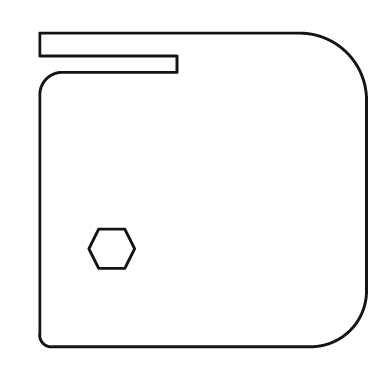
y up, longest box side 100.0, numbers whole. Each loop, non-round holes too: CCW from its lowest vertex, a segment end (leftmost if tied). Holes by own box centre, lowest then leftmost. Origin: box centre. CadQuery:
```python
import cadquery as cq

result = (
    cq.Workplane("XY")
    .moveTo(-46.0, -48.0)
    .lineTo(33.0, -48.0)
    .threePointArc((45.0, -43.0), (50.0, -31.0))
    .lineTo(50.0, 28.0)
    .threePointArc((44.0, 42.0), (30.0, 48.0))
    .lineTo(-50.0, 48.0)
    .lineTo(-50.0, 41.0)
    .lineTo(-8.0, 41.0)
    .lineTo(-8.0, 36.0)
    .lineTo(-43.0, 36.0)
    .threePointArc((-48.0, 34.0), (-50.0, 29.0))
    .lineTo(-50.0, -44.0)
    .threePointArc((-49.0, -47.0), (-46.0, -48.0))
    .close()
    .moveTo(-32.0, -24.0)
    .lineTo(-24.0, -24.0)
    .lineTo(-21.0, -18.0)
    .lineTo(-24.0, -12.0)
    .lineTo(-32.0, -12.0)
    .lineTo(-35.0, -18.0)
    .close()
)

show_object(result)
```